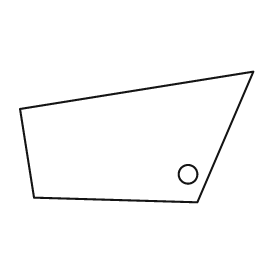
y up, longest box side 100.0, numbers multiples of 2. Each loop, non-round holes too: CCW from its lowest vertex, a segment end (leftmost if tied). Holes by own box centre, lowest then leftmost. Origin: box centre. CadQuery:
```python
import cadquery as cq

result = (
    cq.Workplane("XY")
    .moveTo(26.0, -28.0)
    .lineTo(50.0, 28.0)
    .lineTo(-50.0, 12.0)
    .lineTo(-44.0, -26.0)
    .close()
    .moveTo(22.0, -16.0)
    .circle(4.0)
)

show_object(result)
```